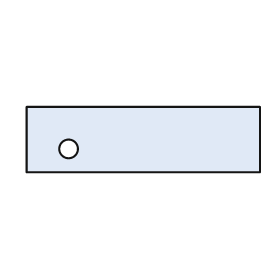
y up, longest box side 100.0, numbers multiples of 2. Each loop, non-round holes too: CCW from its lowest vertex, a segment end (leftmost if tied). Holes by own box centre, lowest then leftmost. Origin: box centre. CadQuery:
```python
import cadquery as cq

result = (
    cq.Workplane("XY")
    .moveTo(-50.0, -14.0)
    .lineTo(50.0, -14.0)
    .lineTo(50.0, 14.0)
    .lineTo(-50.0, 14.0)
    .close()
    .moveTo(-32.0, -4.0)
    .circle(4.0)
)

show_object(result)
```